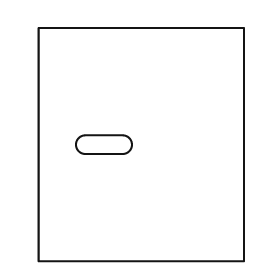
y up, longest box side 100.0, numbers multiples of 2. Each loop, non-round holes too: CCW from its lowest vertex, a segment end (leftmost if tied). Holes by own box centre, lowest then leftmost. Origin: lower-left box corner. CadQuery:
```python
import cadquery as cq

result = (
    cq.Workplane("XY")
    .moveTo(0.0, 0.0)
    .lineTo(88.0, 0.0)
    .lineTo(88.0, 100.0)
    .lineTo(0.0, 100.0)
    .close()
    .moveTo(20.0, 46.0)
    .lineTo(36.0, 46.0)
    .threePointArc((40.0, 50.0), (36.0, 54.0))
    .lineTo(20.0, 54.0)
    .threePointArc((16.0, 50.0), (20.0, 46.0))
    .close()
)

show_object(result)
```